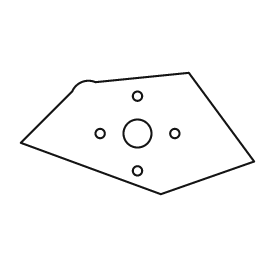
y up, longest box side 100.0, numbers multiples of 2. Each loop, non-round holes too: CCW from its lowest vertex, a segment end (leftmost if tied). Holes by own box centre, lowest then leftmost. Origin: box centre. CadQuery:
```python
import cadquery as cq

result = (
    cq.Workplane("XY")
    .moveTo(10.0, -26.0)
    .lineTo(50.0, -12.0)
    .lineTo(22.0, 26.0)
    .lineTo(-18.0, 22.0)
    .threePointArc((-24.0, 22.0), (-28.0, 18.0))
    .lineTo(-50.0, -4.0)
    .close()
    .moveTo(0.0, -16.0)
    .circle(2.0)
    .moveTo(-16.0, 0.0)
    .circle(2.0)
    .moveTo(0.0, 0.0)
    .circle(6.0)
    .moveTo(16.0, 0.0)
    .circle(2.0)
    .moveTo(0.0, 16.0)
    .circle(2.0)
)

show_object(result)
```